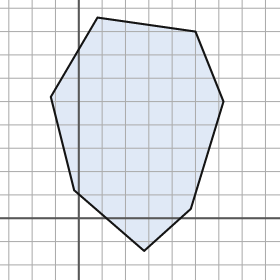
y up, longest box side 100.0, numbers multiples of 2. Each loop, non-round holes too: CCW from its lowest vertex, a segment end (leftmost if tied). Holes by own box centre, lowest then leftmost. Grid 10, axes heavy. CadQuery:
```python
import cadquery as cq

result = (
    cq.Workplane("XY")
    .moveTo(28.0, -14.0)
    .lineTo(48.0, 4.0)
    .lineTo(62.0, 50.0)
    .lineTo(50.0, 80.0)
    .lineTo(8.0, 86.0)
    .lineTo(-12.0, 52.0)
    .lineTo(-2.0, 12.0)
    .close()
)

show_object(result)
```